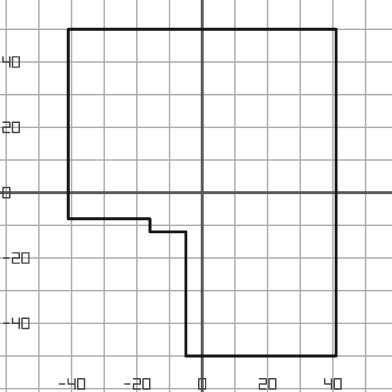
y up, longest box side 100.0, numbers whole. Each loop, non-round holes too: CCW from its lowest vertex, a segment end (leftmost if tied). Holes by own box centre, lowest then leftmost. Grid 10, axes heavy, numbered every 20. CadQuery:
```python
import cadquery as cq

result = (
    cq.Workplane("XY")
    .moveTo(-5.0, -50.0)
    .lineTo(41.0, -50.0)
    .lineTo(41.0, 50.0)
    .lineTo(-41.0, 50.0)
    .lineTo(-41.0, -8.0)
    .lineTo(-16.0, -8.0)
    .lineTo(-16.0, -12.0)
    .lineTo(-5.0, -12.0)
    .close()
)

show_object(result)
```